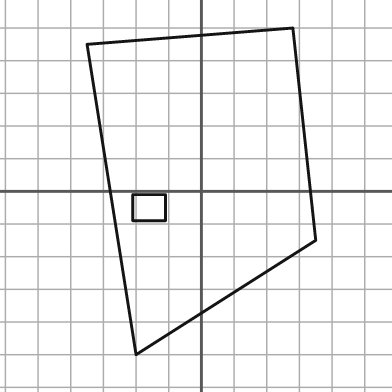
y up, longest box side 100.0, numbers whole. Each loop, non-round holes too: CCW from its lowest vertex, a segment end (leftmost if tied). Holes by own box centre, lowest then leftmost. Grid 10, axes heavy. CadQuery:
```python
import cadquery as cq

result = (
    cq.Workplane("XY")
    .moveTo(-20.0, -50.0)
    .lineTo(35.0, -15.0)
    .lineTo(28.0, 50.0)
    .lineTo(-35.0, 45.0)
    .close()
    .moveTo(-21.0, -9.0)
    .lineTo(-11.0, -9.0)
    .lineTo(-11.0, -1.0)
    .lineTo(-21.0, -1.0)
    .close()
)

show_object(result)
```